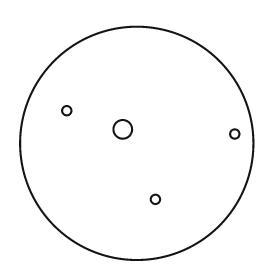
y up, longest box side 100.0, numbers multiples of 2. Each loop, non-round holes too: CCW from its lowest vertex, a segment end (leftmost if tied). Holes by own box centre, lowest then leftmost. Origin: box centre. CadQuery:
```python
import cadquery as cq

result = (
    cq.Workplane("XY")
    .moveTo(0.0, 0.0)
    .circle(50.0)
    .moveTo(8.0, -24.0)
    .circle(2.0)
    .moveTo(42.0, 4.0)
    .circle(2.0)
    .moveTo(-6.0, 6.0)
    .circle(4.0)
    .moveTo(-30.0, 14.0)
    .circle(2.0)
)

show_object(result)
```